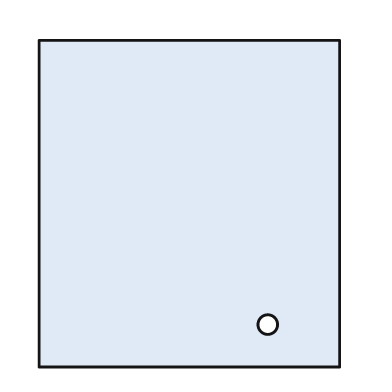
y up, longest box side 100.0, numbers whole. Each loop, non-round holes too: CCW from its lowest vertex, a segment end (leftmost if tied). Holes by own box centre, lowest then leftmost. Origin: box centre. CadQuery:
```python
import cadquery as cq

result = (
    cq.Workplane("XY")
    .moveTo(-46.0, -50.0)
    .lineTo(46.0, -50.0)
    .lineTo(46.0, 50.0)
    .lineTo(-46.0, 50.0)
    .close()
    .moveTo(24.0, -37.0)
    .circle(3.0)
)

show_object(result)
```